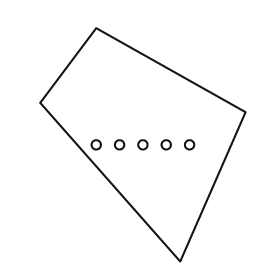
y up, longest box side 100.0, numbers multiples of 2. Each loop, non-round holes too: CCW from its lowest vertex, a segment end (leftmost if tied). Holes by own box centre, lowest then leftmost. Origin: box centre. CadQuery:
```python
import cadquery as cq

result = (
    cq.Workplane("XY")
    .moveTo(16.0, -50.0)
    .lineTo(44.0, 14.0)
    .lineTo(-20.0, 50.0)
    .lineTo(-44.0, 18.0)
    .close()
    .moveTo(-20.0, 0.0)
    .circle(2.0)
    .moveTo(-10.0, 0.0)
    .circle(2.0)
    .moveTo(0.0, 0.0)
    .circle(2.0)
    .moveTo(10.0, 0.0)
    .circle(2.0)
    .moveTo(20.0, 0.0)
    .circle(2.0)
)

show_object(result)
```